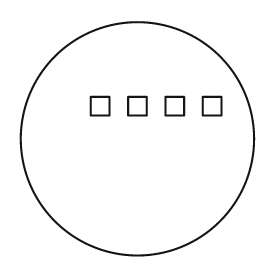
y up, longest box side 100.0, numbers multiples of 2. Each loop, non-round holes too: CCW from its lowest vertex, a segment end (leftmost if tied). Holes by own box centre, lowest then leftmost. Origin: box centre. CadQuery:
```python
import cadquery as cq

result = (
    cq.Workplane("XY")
    .moveTo(0.0, 0.0)
    .circle(50.0)
    .moveTo(-20.0, 10.0)
    .lineTo(-12.0, 10.0)
    .lineTo(-12.0, 18.0)
    .lineTo(-20.0, 18.0)
    .close()
    .moveTo(-4.0, 10.0)
    .lineTo(4.0, 10.0)
    .lineTo(4.0, 18.0)
    .lineTo(-4.0, 18.0)
    .close()
    .moveTo(12.0, 10.0)
    .lineTo(20.0, 10.0)
    .lineTo(20.0, 18.0)
    .lineTo(12.0, 18.0)
    .close()
    .moveTo(28.0, 10.0)
    .lineTo(36.0, 10.0)
    .lineTo(36.0, 18.0)
    .lineTo(28.0, 18.0)
    .close()
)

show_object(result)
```